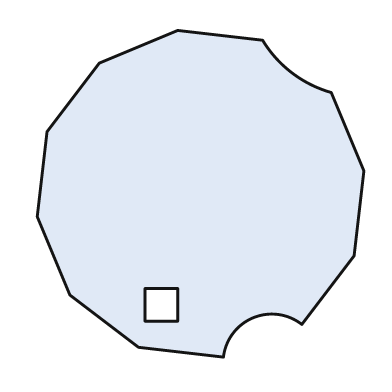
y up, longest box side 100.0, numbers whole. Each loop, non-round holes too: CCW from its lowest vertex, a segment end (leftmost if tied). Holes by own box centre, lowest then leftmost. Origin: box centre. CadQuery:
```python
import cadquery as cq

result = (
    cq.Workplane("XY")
    .moveTo(7.0, -50.0)
    .threePointArc((16.0, -38.0), (31.0, -40.0))
    .lineTo(47.0, -19.0)
    .lineTo(50.0, 7.0)
    .lineTo(40.0, 31.0)
    .threePointArc((28.0, 37.0), (19.0, 47.0))
    .lineTo(-7.0, 50.0)
    .lineTo(-31.0, 40.0)
    .lineTo(-47.0, 19.0)
    .lineTo(-50.0, -7.0)
    .lineTo(-40.0, -31.0)
    .lineTo(-19.0, -47.0)
    .close()
    .moveTo(-17.0, -39.0)
    .lineTo(-7.0, -39.0)
    .lineTo(-7.0, -29.0)
    .lineTo(-17.0, -29.0)
    .close()
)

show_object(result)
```